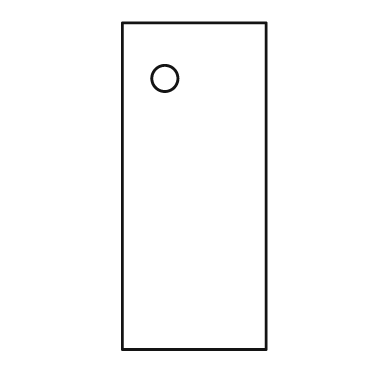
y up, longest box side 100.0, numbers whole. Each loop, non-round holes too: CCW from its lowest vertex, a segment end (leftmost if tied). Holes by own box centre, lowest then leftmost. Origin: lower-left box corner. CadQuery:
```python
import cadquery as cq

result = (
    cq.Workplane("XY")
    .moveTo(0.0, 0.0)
    .lineTo(44.0, 0.0)
    .lineTo(44.0, 100.0)
    .lineTo(0.0, 100.0)
    .close()
    .moveTo(13.0, 83.0)
    .circle(4.0)
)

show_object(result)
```